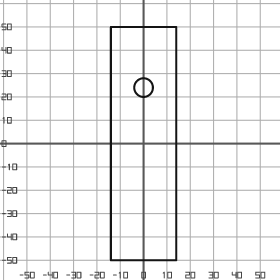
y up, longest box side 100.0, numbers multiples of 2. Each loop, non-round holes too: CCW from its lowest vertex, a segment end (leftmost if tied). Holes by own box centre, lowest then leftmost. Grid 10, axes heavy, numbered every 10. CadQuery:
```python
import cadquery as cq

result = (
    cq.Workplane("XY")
    .moveTo(-14.0, -50.0)
    .lineTo(14.0, -50.0)
    .lineTo(14.0, 50.0)
    .lineTo(-14.0, 50.0)
    .close()
    .moveTo(0.0, 24.0)
    .circle(4.0)
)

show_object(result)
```